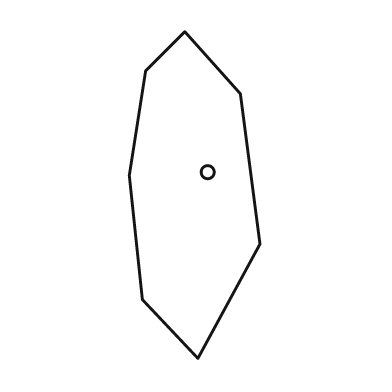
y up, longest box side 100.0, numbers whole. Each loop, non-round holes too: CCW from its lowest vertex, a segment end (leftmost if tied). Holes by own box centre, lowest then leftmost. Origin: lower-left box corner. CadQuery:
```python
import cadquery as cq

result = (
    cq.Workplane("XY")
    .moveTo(21.0, 0.0)
    .lineTo(40.0, 35.0)
    .lineTo(34.0, 81.0)
    .lineTo(17.0, 100.0)
    .lineTo(5.0, 88.0)
    .lineTo(0.0, 56.0)
    .lineTo(4.0, 18.0)
    .close()
    .moveTo(24.0, 57.0)
    .circle(2.0)
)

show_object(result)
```